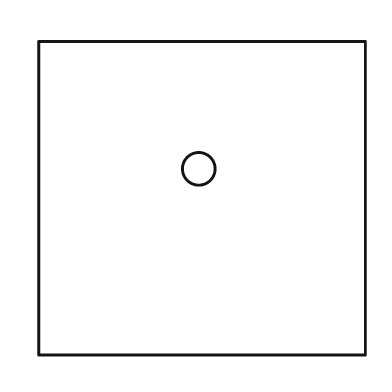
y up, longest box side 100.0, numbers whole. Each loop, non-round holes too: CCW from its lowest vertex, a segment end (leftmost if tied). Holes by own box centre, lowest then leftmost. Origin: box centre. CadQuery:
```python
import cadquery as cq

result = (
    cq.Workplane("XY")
    .moveTo(-50.0, -48.0)
    .lineTo(50.0, -48.0)
    .lineTo(50.0, 48.0)
    .lineTo(-50.0, 48.0)
    .close()
    .moveTo(-1.0, 9.0)
    .circle(5.0)
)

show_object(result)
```